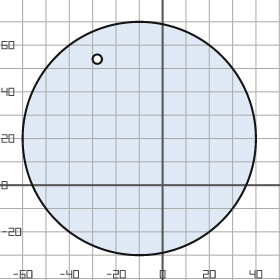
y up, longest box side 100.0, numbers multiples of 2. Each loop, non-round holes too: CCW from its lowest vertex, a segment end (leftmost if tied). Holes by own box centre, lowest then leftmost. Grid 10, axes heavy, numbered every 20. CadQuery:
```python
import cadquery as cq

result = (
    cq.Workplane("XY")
    .moveTo(-10.0, 20.0)
    .circle(50.0)
    .moveTo(-28.0, 54.0)
    .circle(2.0)
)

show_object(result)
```